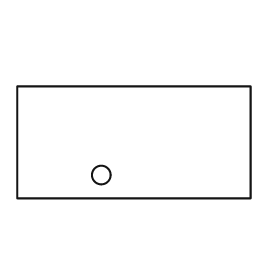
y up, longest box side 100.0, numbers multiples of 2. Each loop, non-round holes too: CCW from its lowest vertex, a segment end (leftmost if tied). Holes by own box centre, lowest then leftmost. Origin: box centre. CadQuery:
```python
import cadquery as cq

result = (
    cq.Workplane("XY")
    .moveTo(-50.0, -24.0)
    .lineTo(50.0, -24.0)
    .lineTo(50.0, 24.0)
    .lineTo(-50.0, 24.0)
    .close()
    .moveTo(-14.0, -14.0)
    .circle(4.0)
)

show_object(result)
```